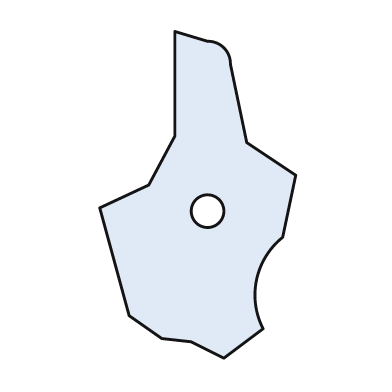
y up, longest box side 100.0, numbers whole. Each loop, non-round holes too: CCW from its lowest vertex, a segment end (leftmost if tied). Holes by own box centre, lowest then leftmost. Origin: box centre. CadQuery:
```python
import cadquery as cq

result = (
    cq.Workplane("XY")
    .moveTo(8.0, -50.0)
    .lineTo(20.0, -41.0)
    .threePointArc((18.0, -26.0), (26.0, -13.0))
    .lineTo(30.0, 6.0)
    .lineTo(15.0, 16.0)
    .lineTo(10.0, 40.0)
    .threePointArc((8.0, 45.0), (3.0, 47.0))
    .lineTo(-7.0, 50.0)
    .lineTo(-7.0, 18.0)
    .lineTo(-15.0, 3.0)
    .lineTo(-30.0, -4.0)
    .lineTo(-21.0, -37.0)
    .lineTo(-11.0, -44.0)
    .lineTo(-2.0, -45.0)
    .close()
    .moveTo(3.0, -5.0)
    .circle(5.0)
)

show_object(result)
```